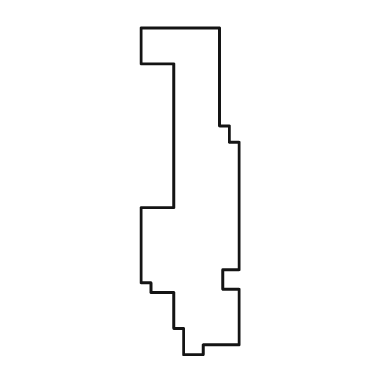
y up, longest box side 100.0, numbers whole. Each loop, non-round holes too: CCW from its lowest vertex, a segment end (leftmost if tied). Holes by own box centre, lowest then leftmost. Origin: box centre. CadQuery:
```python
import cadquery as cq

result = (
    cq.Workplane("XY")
    .moveTo(-2.0, -50.0)
    .lineTo(4.0, -50.0)
    .lineTo(4.0, -47.0)
    .lineTo(15.0, -47.0)
    .lineTo(15.0, -30.0)
    .lineTo(10.0, -30.0)
    .lineTo(10.0, -24.0)
    .lineTo(15.0, -24.0)
    .lineTo(15.0, 15.0)
    .lineTo(12.0, 15.0)
    .lineTo(12.0, 20.0)
    .lineTo(9.0, 20.0)
    .lineTo(9.0, 50.0)
    .lineTo(-15.0, 50.0)
    .lineTo(-15.0, 39.0)
    .lineTo(-5.0, 39.0)
    .lineTo(-5.0, -5.0)
    .lineTo(-15.0, -5.0)
    .lineTo(-15.0, -28.0)
    .lineTo(-12.0, -28.0)
    .lineTo(-12.0, -31.0)
    .lineTo(-5.0, -31.0)
    .lineTo(-5.0, -42.0)
    .lineTo(-2.0, -42.0)
    .close()
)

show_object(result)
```